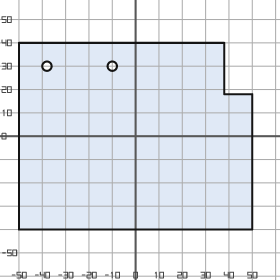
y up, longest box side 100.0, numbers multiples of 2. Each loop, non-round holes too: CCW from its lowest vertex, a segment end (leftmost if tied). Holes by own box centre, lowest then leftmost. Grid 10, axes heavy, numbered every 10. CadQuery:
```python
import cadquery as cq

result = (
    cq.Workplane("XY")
    .moveTo(-50.0, -40.0)
    .lineTo(50.0, -40.0)
    .lineTo(50.0, 18.0)
    .lineTo(38.0, 18.0)
    .lineTo(38.0, 40.0)
    .lineTo(-50.0, 40.0)
    .close()
    .moveTo(-38.0, 30.0)
    .circle(2.0)
    .moveTo(-10.0, 30.0)
    .circle(2.0)
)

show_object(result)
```